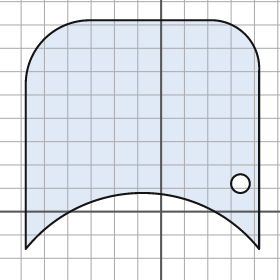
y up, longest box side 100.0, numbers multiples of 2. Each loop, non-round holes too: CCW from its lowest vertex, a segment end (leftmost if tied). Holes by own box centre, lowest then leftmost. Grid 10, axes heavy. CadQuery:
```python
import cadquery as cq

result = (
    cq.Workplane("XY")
    .moveTo(-58.0, -16.0)
    .threePointArc((-8.0, 8.0), (42.0, -16.0))
    .lineTo(42.0, 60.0)
    .threePointArc((36.0, 76.0), (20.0, 82.0))
    .lineTo(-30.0, 82.0)
    .threePointArc((-50.0, 74.0), (-58.0, 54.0))
    .close()
    .moveTo(34.0, 12.0)
    .circle(4.0)
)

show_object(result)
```